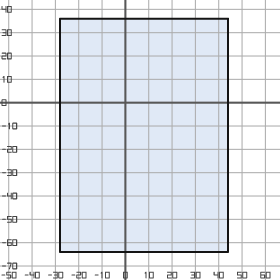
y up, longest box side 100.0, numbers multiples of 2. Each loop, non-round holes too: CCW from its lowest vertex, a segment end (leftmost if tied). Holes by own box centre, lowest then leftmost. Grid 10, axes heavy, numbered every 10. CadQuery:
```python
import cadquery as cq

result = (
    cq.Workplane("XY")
    .moveTo(-28.0, -64.0)
    .lineTo(44.0, -64.0)
    .lineTo(44.0, 36.0)
    .lineTo(-28.0, 36.0)
    .close()
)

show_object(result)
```